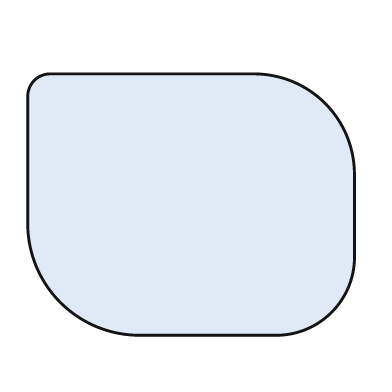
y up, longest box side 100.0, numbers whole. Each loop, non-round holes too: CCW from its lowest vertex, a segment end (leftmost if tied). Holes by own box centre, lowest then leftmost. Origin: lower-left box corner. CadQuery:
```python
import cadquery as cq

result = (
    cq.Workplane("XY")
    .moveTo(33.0, 0.0)
    .lineTo(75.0, 0.0)
    .threePointArc((93.0, 7.0), (100.0, 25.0))
    .lineTo(100.0, 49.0)
    .threePointArc((91.0, 71.0), (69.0, 80.0))
    .lineTo(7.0, 80.0)
    .threePointArc((2.0, 78.0), (0.0, 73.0))
    .lineTo(0.0, 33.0)
    .threePointArc((10.0, 10.0), (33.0, 0.0))
    .close()
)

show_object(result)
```